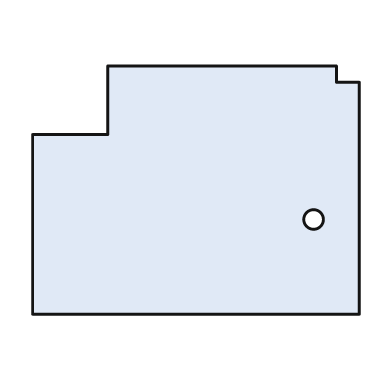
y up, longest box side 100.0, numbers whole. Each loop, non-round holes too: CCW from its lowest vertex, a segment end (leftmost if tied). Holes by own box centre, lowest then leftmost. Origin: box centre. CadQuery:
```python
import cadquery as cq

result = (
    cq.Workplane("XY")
    .moveTo(-50.0, -38.0)
    .lineTo(50.0, -38.0)
    .lineTo(50.0, 33.0)
    .lineTo(43.0, 33.0)
    .lineTo(43.0, 38.0)
    .lineTo(-27.0, 38.0)
    .lineTo(-27.0, 17.0)
    .lineTo(-50.0, 17.0)
    .close()
    .moveTo(36.0, -9.0)
    .circle(3.0)
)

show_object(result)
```